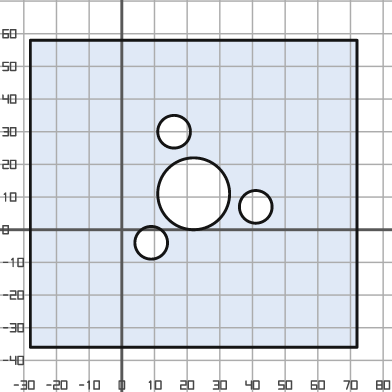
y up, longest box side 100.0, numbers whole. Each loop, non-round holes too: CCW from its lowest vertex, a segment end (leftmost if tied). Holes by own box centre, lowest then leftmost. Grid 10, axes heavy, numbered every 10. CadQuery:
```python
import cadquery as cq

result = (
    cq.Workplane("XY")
    .moveTo(-28.0, -36.0)
    .lineTo(72.0, -36.0)
    .lineTo(72.0, 58.0)
    .lineTo(-28.0, 58.0)
    .close()
    .moveTo(9.0, -4.0)
    .circle(5.0)
    .moveTo(41.0, 7.0)
    .circle(5.0)
    .moveTo(22.0, 11.0)
    .circle(11.0)
    .moveTo(16.0, 30.0)
    .circle(5.0)
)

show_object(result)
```